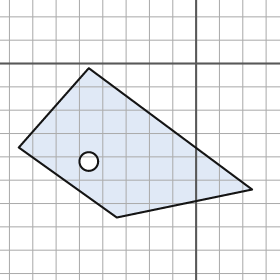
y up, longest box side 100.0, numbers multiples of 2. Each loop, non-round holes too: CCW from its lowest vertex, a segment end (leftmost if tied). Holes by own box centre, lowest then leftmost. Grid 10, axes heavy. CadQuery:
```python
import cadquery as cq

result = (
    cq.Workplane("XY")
    .moveTo(-34.0, -66.0)
    .lineTo(24.0, -54.0)
    .lineTo(-46.0, -2.0)
    .lineTo(-76.0, -36.0)
    .close()
    .moveTo(-46.0, -42.0)
    .circle(4.0)
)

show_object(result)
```